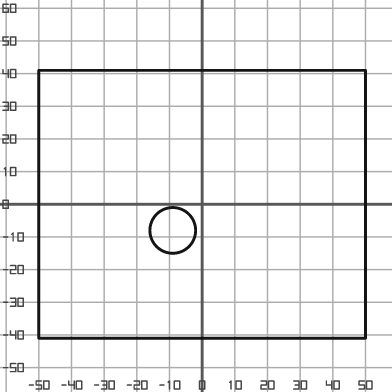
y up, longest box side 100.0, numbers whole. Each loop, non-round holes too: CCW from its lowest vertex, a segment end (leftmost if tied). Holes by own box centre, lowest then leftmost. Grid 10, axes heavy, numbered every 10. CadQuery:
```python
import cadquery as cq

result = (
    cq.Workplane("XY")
    .moveTo(-50.0, -41.0)
    .lineTo(50.0, -41.0)
    .lineTo(50.0, 41.0)
    .lineTo(-50.0, 41.0)
    .close()
    .moveTo(-9.0, -8.0)
    .circle(7.0)
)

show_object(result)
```